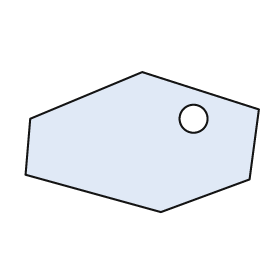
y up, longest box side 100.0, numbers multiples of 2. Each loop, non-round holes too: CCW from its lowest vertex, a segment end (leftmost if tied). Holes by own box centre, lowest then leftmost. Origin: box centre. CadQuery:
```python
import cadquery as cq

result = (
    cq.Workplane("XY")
    .moveTo(8.0, -30.0)
    .lineTo(46.0, -16.0)
    .lineTo(50.0, 14.0)
    .lineTo(0.0, 30.0)
    .lineTo(-48.0, 10.0)
    .lineTo(-50.0, -14.0)
    .close()
    .moveTo(22.0, 10.0)
    .circle(6.0)
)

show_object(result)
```